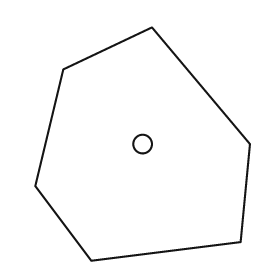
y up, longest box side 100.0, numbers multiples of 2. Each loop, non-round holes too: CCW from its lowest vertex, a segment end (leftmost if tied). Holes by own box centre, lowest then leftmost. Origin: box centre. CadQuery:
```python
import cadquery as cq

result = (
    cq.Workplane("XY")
    .moveTo(-22.0, -50.0)
    .lineTo(42.0, -42.0)
    .lineTo(46.0, 0.0)
    .lineTo(4.0, 50.0)
    .lineTo(-34.0, 32.0)
    .lineTo(-46.0, -18.0)
    .close()
    .moveTo(0.0, 0.0)
    .circle(4.0)
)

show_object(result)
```